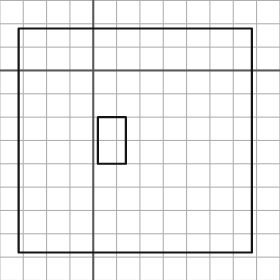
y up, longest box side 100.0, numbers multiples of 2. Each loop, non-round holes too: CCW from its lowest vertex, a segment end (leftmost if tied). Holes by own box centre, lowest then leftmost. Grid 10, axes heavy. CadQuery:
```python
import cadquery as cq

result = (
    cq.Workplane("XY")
    .moveTo(-32.0, -78.0)
    .lineTo(68.0, -78.0)
    .lineTo(68.0, 18.0)
    .lineTo(-32.0, 18.0)
    .close()
    .moveTo(2.0, -40.0)
    .lineTo(14.0, -40.0)
    .lineTo(14.0, -20.0)
    .lineTo(2.0, -20.0)
    .close()
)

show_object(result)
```